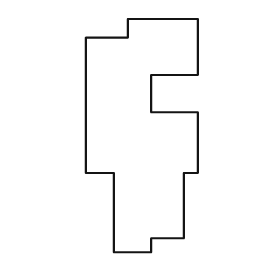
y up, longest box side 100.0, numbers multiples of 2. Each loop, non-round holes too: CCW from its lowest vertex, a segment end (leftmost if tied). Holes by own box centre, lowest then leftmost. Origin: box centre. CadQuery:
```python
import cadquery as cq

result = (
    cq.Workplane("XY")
    .moveTo(-12.0, -50.0)
    .lineTo(4.0, -50.0)
    .lineTo(4.0, -44.0)
    .lineTo(18.0, -44.0)
    .lineTo(18.0, -16.0)
    .lineTo(24.0, -16.0)
    .lineTo(24.0, 10.0)
    .lineTo(4.0, 10.0)
    .lineTo(4.0, 26.0)
    .lineTo(24.0, 26.0)
    .lineTo(24.0, 50.0)
    .lineTo(-6.0, 50.0)
    .lineTo(-6.0, 42.0)
    .lineTo(-24.0, 42.0)
    .lineTo(-24.0, -16.0)
    .lineTo(-12.0, -16.0)
    .close()
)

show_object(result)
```